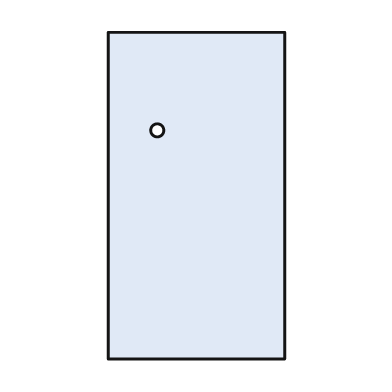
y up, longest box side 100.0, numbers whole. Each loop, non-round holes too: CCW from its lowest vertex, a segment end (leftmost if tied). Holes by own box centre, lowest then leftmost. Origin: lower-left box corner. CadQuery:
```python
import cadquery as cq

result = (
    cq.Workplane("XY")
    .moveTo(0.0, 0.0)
    .lineTo(54.0, 0.0)
    .lineTo(54.0, 100.0)
    .lineTo(0.0, 100.0)
    .close()
    .moveTo(15.0, 70.0)
    .circle(2.0)
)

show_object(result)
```